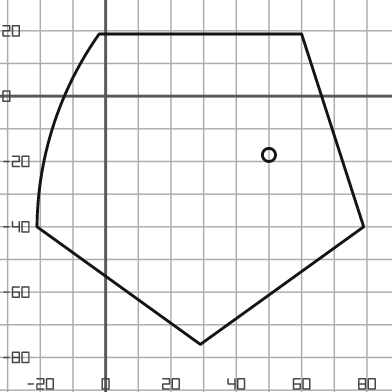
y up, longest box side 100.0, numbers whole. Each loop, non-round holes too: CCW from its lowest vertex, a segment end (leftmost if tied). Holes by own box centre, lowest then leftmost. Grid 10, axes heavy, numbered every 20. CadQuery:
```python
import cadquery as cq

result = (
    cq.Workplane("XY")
    .moveTo(29.0, -76.0)
    .lineTo(79.0, -40.0)
    .lineTo(60.0, 19.0)
    .lineTo(-2.0, 19.0)
    .threePointArc((-16.0, -9.0), (-21.0, -40.0))
    .close()
    .moveTo(50.0, -18.0)
    .circle(2.0)
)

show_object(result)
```